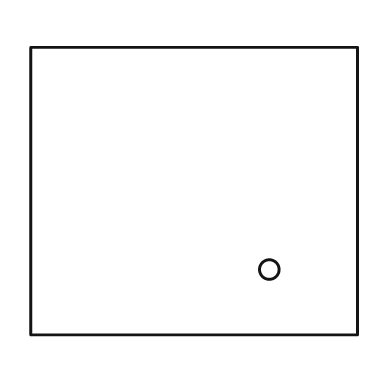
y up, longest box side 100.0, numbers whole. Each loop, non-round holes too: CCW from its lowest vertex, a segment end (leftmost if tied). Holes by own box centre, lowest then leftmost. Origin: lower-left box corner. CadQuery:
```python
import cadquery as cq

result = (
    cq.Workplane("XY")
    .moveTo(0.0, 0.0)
    .lineTo(100.0, 0.0)
    .lineTo(100.0, 88.0)
    .lineTo(0.0, 88.0)
    .close()
    .moveTo(73.0, 20.0)
    .circle(3.0)
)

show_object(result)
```